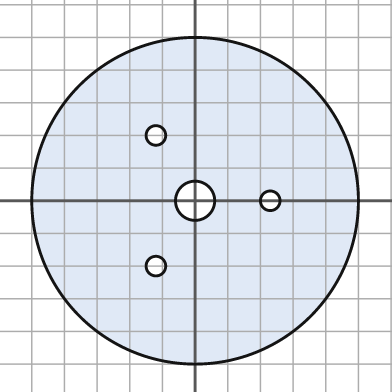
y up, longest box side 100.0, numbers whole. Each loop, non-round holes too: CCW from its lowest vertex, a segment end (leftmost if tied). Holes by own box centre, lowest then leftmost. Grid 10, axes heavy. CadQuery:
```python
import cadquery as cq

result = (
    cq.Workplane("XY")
    .moveTo(0.0, 0.0)
    .circle(50.0)
    .moveTo(-12.0, -20.0)
    .circle(3.0)
    .moveTo(0.0, 0.0)
    .circle(6.0)
    .moveTo(23.0, 0.0)
    .circle(3.0)
    .moveTo(-12.0, 20.0)
    .circle(3.0)
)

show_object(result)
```